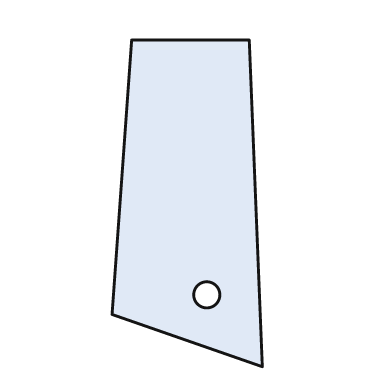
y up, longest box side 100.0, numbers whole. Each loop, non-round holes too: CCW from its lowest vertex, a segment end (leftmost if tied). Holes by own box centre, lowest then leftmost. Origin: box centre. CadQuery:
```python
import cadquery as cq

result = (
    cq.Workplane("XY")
    .moveTo(23.0, -50.0)
    .lineTo(19.0, 50.0)
    .lineTo(-17.0, 50.0)
    .lineTo(-23.0, -34.0)
    .close()
    .moveTo(6.0, -28.0)
    .circle(4.0)
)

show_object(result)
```